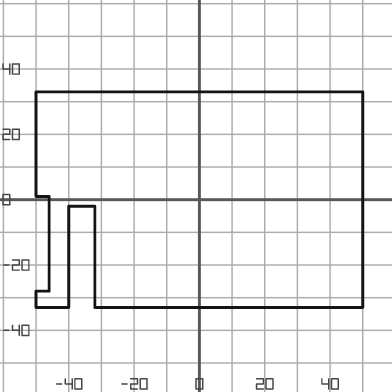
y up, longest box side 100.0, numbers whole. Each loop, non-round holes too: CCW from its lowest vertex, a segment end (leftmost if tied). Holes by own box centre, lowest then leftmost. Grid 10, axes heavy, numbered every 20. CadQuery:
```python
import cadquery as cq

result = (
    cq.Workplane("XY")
    .moveTo(-50.0, -33.0)
    .lineTo(-40.0, -33.0)
    .lineTo(-40.0, -2.0)
    .lineTo(-32.0, -2.0)
    .lineTo(-32.0, -33.0)
    .lineTo(50.0, -33.0)
    .lineTo(50.0, 33.0)
    .lineTo(-50.0, 33.0)
    .lineTo(-50.0, 1.0)
    .lineTo(-46.0, 1.0)
    .lineTo(-46.0, -28.0)
    .lineTo(-50.0, -28.0)
    .close()
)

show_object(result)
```